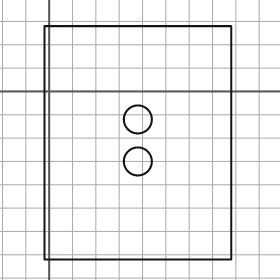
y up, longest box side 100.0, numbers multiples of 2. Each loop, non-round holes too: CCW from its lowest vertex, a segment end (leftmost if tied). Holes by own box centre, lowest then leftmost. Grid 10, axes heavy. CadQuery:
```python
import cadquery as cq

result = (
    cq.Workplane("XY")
    .moveTo(-2.0, -72.0)
    .lineTo(78.0, -72.0)
    .lineTo(78.0, 28.0)
    .lineTo(-2.0, 28.0)
    .close()
    .moveTo(38.0, -30.0)
    .circle(6.0)
    .moveTo(38.0, -12.0)
    .circle(6.0)
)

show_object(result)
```